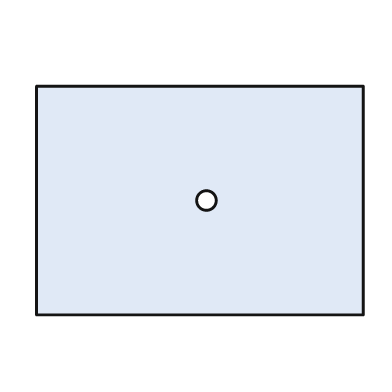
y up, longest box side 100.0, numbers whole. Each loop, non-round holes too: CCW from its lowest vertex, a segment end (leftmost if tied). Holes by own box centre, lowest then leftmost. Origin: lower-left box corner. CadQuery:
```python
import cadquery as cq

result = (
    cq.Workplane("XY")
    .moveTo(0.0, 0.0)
    .lineTo(100.0, 0.0)
    .lineTo(100.0, 70.0)
    .lineTo(0.0, 70.0)
    .close()
    .moveTo(52.0, 35.0)
    .circle(3.0)
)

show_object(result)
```